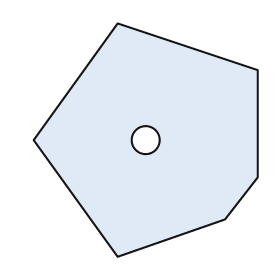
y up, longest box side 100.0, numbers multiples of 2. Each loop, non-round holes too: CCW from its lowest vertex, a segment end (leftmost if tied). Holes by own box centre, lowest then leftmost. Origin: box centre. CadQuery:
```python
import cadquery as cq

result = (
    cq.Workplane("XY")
    .moveTo(-12.0, -50.0)
    .lineTo(34.0, -34.0)
    .lineTo(48.0, -16.0)
    .lineTo(48.0, 30.0)
    .lineTo(-12.0, 50.0)
    .lineTo(-48.0, 0.0)
    .close()
    .moveTo(0.0, 0.0)
    .circle(6.0)
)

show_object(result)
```